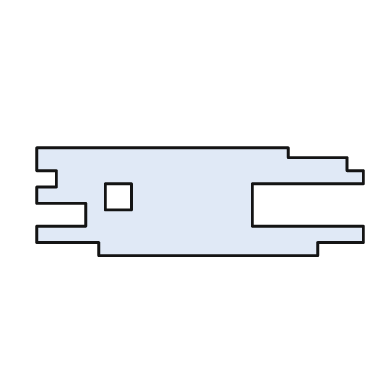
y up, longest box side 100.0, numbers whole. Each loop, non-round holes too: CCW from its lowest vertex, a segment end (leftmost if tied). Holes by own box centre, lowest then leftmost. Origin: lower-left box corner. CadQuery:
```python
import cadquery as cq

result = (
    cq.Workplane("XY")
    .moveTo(19.0, 0.0)
    .lineTo(86.0, 0.0)
    .lineTo(86.0, 4.0)
    .lineTo(100.0, 4.0)
    .lineTo(100.0, 9.0)
    .lineTo(66.0, 9.0)
    .lineTo(66.0, 22.0)
    .lineTo(100.0, 22.0)
    .lineTo(100.0, 26.0)
    .lineTo(95.0, 26.0)
    .lineTo(95.0, 30.0)
    .lineTo(77.0, 30.0)
    .lineTo(77.0, 33.0)
    .lineTo(0.0, 33.0)
    .lineTo(0.0, 26.0)
    .lineTo(6.0, 26.0)
    .lineTo(6.0, 21.0)
    .lineTo(0.0, 21.0)
    .lineTo(0.0, 16.0)
    .lineTo(15.0, 16.0)
    .lineTo(15.0, 9.0)
    .lineTo(0.0, 9.0)
    .lineTo(0.0, 4.0)
    .lineTo(19.0, 4.0)
    .close()
    .moveTo(21.0, 14.0)
    .lineTo(29.0, 14.0)
    .lineTo(29.0, 22.0)
    .lineTo(21.0, 22.0)
    .close()
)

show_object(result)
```